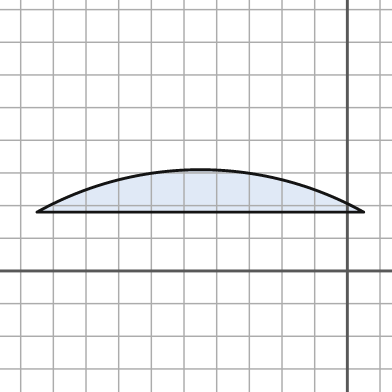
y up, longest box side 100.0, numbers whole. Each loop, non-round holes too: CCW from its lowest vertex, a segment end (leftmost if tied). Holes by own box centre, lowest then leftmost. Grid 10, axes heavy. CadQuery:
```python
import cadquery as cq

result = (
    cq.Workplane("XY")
    .moveTo(-95.0, 18.0)
    .lineTo(5.0, 18.0)
    .threePointArc((-45.0, 31.0), (-95.0, 18.0))
    .close()
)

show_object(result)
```